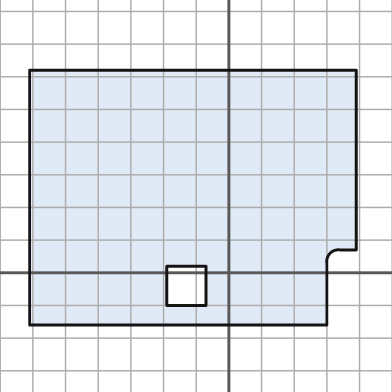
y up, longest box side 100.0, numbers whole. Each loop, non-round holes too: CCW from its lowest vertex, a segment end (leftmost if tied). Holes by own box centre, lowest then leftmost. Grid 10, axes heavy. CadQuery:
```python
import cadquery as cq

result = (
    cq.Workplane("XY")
    .moveTo(-61.0, -16.0)
    .lineTo(30.0, -16.0)
    .lineTo(30.0, 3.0)
    .threePointArc((31.0, 6.0), (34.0, 7.0))
    .lineTo(39.0, 7.0)
    .lineTo(39.0, 62.0)
    .lineTo(-61.0, 62.0)
    .close()
    .moveTo(-19.0, -10.0)
    .lineTo(-7.0, -10.0)
    .lineTo(-7.0, 2.0)
    .lineTo(-19.0, 2.0)
    .close()
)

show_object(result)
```